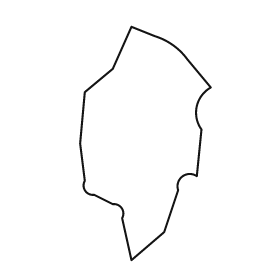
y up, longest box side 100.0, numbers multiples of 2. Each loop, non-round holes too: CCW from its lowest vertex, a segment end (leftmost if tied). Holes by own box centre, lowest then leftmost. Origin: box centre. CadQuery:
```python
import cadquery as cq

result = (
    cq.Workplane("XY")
    .moveTo(-6.0, -50.0)
    .lineTo(8.0, -38.0)
    .lineTo(14.0, -20.0)
    .threePointArc((16.0, -14.0), (22.0, -14.0))
    .lineTo(24.0, 6.0)
    .threePointArc((22.0, 16.0), (28.0, 24.0))
    .lineTo(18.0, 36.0)
    .threePointArc((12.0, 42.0), (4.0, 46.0))
    .lineTo(-6.0, 50.0)
    .lineTo(-14.0, 32.0)
    .lineTo(-26.0, 22.0)
    .lineTo(-28.0, 0.0)
    .lineTo(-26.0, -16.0)
    .threePointArc((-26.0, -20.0), (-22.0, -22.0))
    .lineTo(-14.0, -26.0)
    .threePointArc((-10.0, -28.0), (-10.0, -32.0))
    .close()
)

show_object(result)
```